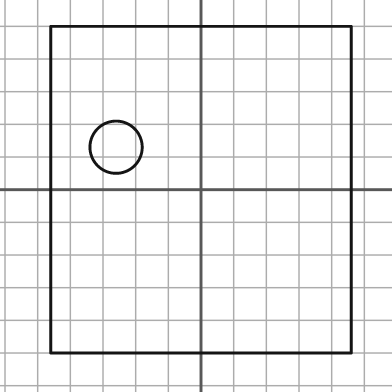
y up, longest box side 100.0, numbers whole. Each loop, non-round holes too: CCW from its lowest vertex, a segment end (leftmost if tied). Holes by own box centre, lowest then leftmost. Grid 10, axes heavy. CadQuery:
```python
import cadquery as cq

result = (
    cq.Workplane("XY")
    .moveTo(-46.0, -50.0)
    .lineTo(46.0, -50.0)
    .lineTo(46.0, 50.0)
    .lineTo(-46.0, 50.0)
    .close()
    .moveTo(-26.0, 13.0)
    .circle(8.0)
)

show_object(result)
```